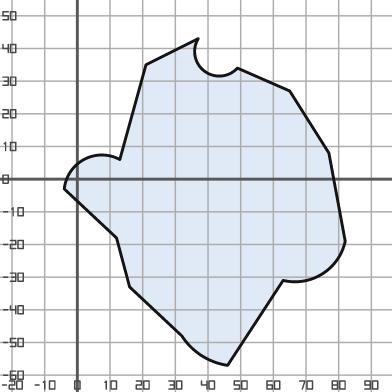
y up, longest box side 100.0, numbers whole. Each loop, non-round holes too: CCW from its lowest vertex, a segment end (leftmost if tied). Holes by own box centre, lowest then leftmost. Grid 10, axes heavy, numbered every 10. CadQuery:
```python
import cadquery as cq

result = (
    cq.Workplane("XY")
    .moveTo(46.0, -57.0)
    .lineTo(63.0, -31.0)
    .threePointArc((75.0, -29.0), (82.0, -19.0))
    .lineTo(77.0, 8.0)
    .lineTo(65.0, 27.0)
    .lineTo(49.0, 34.0)
    .threePointArc((39.0, 33.0), (37.0, 43.0))
    .lineTo(21.0, 35.0)
    .lineTo(13.0, 6.0)
    .threePointArc((2.0, 6.0), (-4.0, -3.0))
    .lineTo(12.0, -18.0)
    .lineTo(16.0, -33.0)
    .lineTo(32.0, -48.0)
    .threePointArc((38.0, -54.0), (46.0, -57.0))
    .close()
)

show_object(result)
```